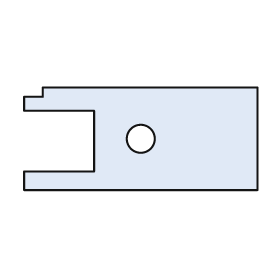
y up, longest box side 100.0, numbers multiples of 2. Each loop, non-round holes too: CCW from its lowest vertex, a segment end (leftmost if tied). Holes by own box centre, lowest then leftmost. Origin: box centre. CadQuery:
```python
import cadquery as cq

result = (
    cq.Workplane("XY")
    .moveTo(-50.0, -22.0)
    .lineTo(50.0, -22.0)
    .lineTo(50.0, 22.0)
    .lineTo(-42.0, 22.0)
    .lineTo(-42.0, 18.0)
    .lineTo(-50.0, 18.0)
    .lineTo(-50.0, 12.0)
    .lineTo(-20.0, 12.0)
    .lineTo(-20.0, -14.0)
    .lineTo(-50.0, -14.0)
    .close()
    .moveTo(0.0, 0.0)
    .circle(6.0)
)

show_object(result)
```